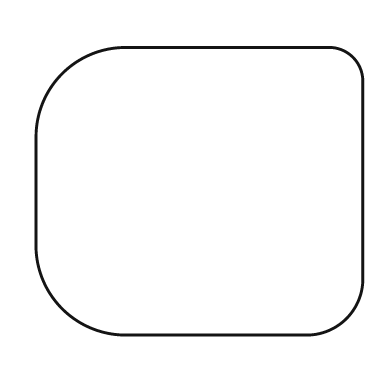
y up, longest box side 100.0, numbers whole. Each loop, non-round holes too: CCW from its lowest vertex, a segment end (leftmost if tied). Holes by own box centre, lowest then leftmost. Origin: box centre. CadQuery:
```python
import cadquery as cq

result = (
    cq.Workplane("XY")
    .moveTo(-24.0, -44.0)
    .lineTo(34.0, -44.0)
    .threePointArc((45.0, -39.0), (50.0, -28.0))
    .lineTo(50.0, 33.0)
    .threePointArc((47.0, 41.0), (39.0, 44.0))
    .lineTo(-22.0, 44.0)
    .threePointArc((-42.0, 36.0), (-50.0, 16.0))
    .lineTo(-50.0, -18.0)
    .threePointArc((-42.0, -36.0), (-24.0, -44.0))
    .close()
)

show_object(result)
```